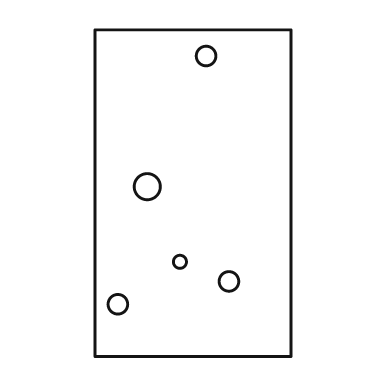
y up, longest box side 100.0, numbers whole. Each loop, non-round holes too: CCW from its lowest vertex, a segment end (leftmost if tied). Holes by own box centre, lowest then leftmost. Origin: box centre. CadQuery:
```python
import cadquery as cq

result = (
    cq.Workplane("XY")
    .moveTo(-30.0, -50.0)
    .lineTo(30.0, -50.0)
    .lineTo(30.0, 50.0)
    .lineTo(-30.0, 50.0)
    .close()
    .moveTo(-23.0, -34.0)
    .circle(3.0)
    .moveTo(11.0, -27.0)
    .circle(3.0)
    .moveTo(-4.0, -21.0)
    .circle(2.0)
    .moveTo(-14.0, 2.0)
    .circle(4.0)
    .moveTo(4.0, 42.0)
    .circle(3.0)
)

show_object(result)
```